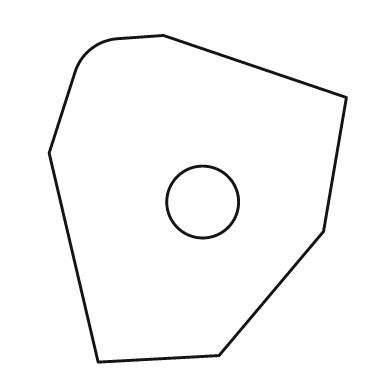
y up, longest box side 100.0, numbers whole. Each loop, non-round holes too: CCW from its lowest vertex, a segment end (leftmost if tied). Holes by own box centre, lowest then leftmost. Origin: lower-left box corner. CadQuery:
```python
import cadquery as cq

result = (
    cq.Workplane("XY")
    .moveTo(15.0, 0.0)
    .lineTo(52.0, 2.0)
    .lineTo(84.0, 40.0)
    .lineTo(91.0, 81.0)
    .lineTo(35.0, 100.0)
    .lineTo(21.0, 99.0)
    .threePointArc((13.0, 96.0), (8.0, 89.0))
    .lineTo(0.0, 64.0)
    .close()
    .moveTo(47.0, 49.0)
    .circle(11.0)
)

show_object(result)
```